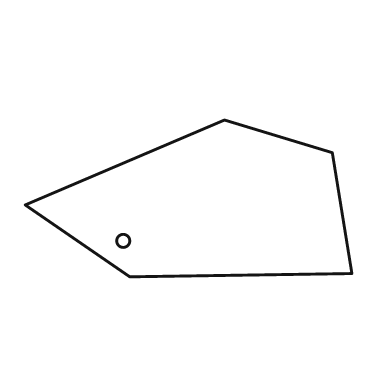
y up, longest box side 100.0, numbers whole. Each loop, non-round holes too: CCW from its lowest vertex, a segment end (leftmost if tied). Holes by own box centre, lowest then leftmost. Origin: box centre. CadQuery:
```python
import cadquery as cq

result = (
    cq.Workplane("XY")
    .moveTo(-18.0, -24.0)
    .lineTo(50.0, -23.0)
    .lineTo(44.0, 14.0)
    .lineTo(11.0, 24.0)
    .lineTo(-50.0, -2.0)
    .close()
    .moveTo(-20.0, -13.0)
    .circle(2.0)
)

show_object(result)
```